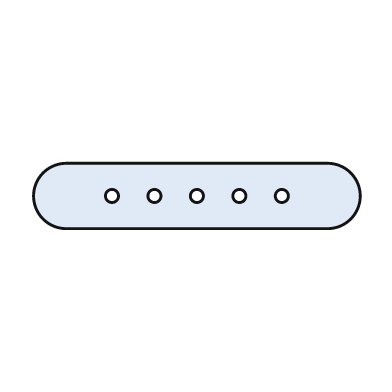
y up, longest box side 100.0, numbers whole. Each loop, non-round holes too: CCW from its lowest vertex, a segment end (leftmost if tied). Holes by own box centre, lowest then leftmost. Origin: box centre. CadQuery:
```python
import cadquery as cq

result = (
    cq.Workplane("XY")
    .moveTo(-40.0, -10.0)
    .lineTo(40.0, -10.0)
    .threePointArc((50.0, 0.0), (40.0, 10.0))
    .lineTo(-40.0, 10.0)
    .threePointArc((-50.0, 0.0), (-40.0, -10.0))
    .close()
    .moveTo(-26.0, 0.0)
    .circle(2.0)
    .moveTo(-13.0, 0.0)
    .circle(2.0)
    .moveTo(0.0, 0.0)
    .circle(2.0)
    .moveTo(13.0, 0.0)
    .circle(2.0)
    .moveTo(26.0, 0.0)
    .circle(2.0)
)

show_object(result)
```